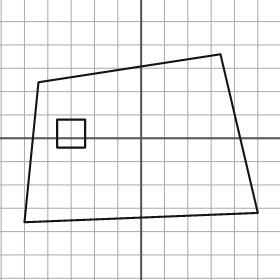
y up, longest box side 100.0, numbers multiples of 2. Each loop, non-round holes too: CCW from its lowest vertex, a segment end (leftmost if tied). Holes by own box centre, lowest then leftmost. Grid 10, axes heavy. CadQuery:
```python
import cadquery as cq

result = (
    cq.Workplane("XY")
    .moveTo(-50.0, -36.0)
    .lineTo(50.0, -32.0)
    .lineTo(34.0, 36.0)
    .lineTo(-44.0, 24.0)
    .close()
    .moveTo(-36.0, -4.0)
    .lineTo(-24.0, -4.0)
    .lineTo(-24.0, 8.0)
    .lineTo(-36.0, 8.0)
    .close()
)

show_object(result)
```